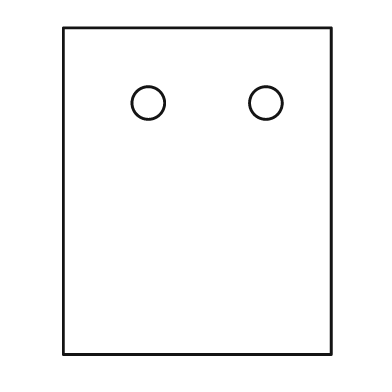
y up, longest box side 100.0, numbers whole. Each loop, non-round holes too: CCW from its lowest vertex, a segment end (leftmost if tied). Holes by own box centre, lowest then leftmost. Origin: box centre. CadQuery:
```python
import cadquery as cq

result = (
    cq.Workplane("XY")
    .moveTo(-41.0, -50.0)
    .lineTo(41.0, -50.0)
    .lineTo(41.0, 50.0)
    .lineTo(-41.0, 50.0)
    .close()
    .moveTo(-15.0, 27.0)
    .circle(5.0)
    .moveTo(21.0, 27.0)
    .circle(5.0)
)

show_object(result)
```